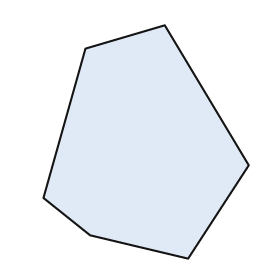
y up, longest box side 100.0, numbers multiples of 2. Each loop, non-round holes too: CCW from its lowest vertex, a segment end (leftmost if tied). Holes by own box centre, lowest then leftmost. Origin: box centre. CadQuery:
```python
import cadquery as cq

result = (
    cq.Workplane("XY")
    .moveTo(18.0, -50.0)
    .lineTo(44.0, -10.0)
    .lineTo(8.0, 50.0)
    .lineTo(-26.0, 40.0)
    .lineTo(-44.0, -24.0)
    .lineTo(-24.0, -40.0)
    .close()
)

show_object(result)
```